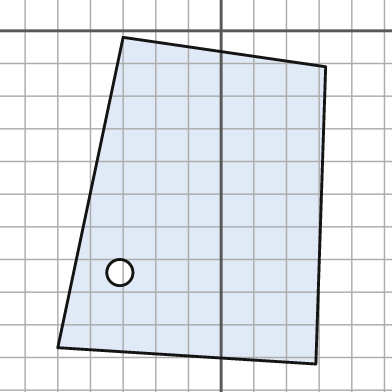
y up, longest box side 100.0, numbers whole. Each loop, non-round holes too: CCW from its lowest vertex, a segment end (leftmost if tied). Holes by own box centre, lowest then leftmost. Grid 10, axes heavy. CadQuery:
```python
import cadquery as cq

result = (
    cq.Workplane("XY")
    .moveTo(29.0, -102.0)
    .lineTo(32.0, -11.0)
    .lineTo(-30.0, -2.0)
    .lineTo(-50.0, -97.0)
    .close()
    .moveTo(-31.0, -74.0)
    .circle(4.0)
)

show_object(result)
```